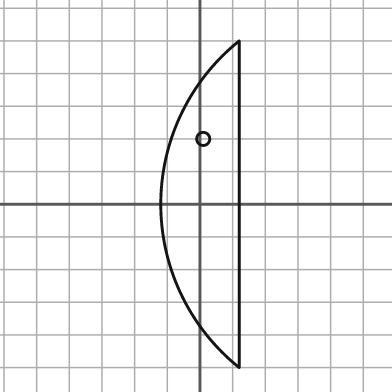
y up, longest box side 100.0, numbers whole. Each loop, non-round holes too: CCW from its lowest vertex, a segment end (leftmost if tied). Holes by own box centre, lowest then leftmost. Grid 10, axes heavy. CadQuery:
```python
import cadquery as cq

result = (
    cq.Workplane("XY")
    .moveTo(12.0, -50.0)
    .lineTo(12.0, 50.0)
    .threePointArc((-12.0, 0.0), (12.0, -50.0))
    .close()
    .moveTo(1.0, 20.0)
    .circle(2.0)
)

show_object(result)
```